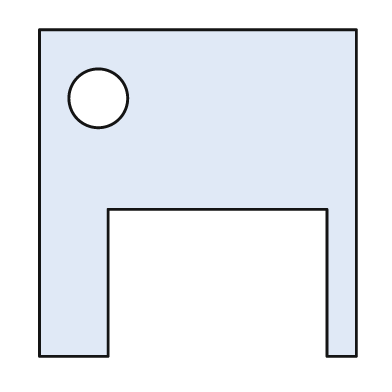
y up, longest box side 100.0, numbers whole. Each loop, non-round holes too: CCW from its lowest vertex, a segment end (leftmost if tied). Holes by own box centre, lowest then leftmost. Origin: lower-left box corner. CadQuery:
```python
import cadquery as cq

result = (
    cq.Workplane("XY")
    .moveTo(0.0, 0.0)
    .lineTo(21.0, 0.0)
    .lineTo(21.0, 45.0)
    .lineTo(88.0, 45.0)
    .lineTo(88.0, 0.0)
    .lineTo(97.0, 0.0)
    .lineTo(97.0, 100.0)
    .lineTo(0.0, 100.0)
    .close()
    .moveTo(18.0, 79.0)
    .circle(9.0)
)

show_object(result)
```